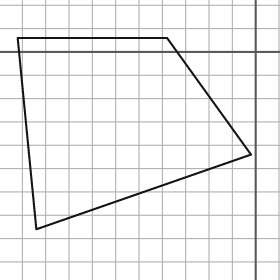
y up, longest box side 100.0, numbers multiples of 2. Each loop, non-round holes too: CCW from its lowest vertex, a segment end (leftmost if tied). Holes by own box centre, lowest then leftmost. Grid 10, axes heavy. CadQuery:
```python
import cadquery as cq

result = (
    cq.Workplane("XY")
    .moveTo(-94.0, -76.0)
    .lineTo(-2.0, -44.0)
    .lineTo(-38.0, 6.0)
    .lineTo(-102.0, 6.0)
    .close()
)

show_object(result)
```